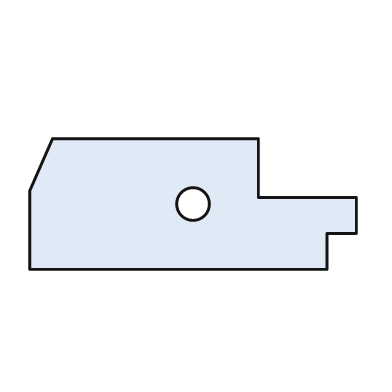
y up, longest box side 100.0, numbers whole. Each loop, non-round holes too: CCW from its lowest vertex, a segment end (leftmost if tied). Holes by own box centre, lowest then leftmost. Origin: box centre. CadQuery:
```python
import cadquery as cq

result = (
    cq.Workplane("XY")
    .moveTo(-50.0, -20.0)
    .lineTo(41.0, -20.0)
    .lineTo(41.0, -9.0)
    .lineTo(50.0, -9.0)
    .lineTo(50.0, 2.0)
    .lineTo(20.0, 2.0)
    .lineTo(20.0, 20.0)
    .lineTo(-43.0, 20.0)
    .lineTo(-50.0, 4.0)
    .close()
    .moveTo(0.0, 0.0)
    .circle(5.0)
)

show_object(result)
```